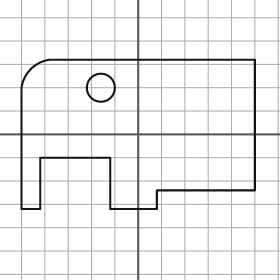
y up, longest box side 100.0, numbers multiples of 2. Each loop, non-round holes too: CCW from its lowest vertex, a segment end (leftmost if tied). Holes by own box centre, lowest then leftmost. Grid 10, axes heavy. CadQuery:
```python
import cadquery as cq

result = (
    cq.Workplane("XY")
    .moveTo(-50.0, -32.0)
    .lineTo(-42.0, -32.0)
    .lineTo(-42.0, -10.0)
    .lineTo(-12.0, -10.0)
    .lineTo(-12.0, -32.0)
    .lineTo(8.0, -32.0)
    .lineTo(8.0, -24.0)
    .lineTo(50.0, -24.0)
    .lineTo(50.0, 32.0)
    .lineTo(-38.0, 32.0)
    .threePointArc((-46.0, 28.0), (-50.0, 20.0))
    .close()
    .moveTo(-16.0, 20.0)
    .circle(6.0)
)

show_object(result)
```